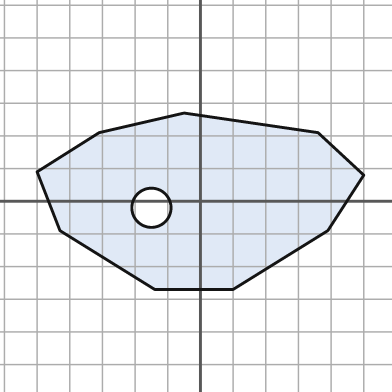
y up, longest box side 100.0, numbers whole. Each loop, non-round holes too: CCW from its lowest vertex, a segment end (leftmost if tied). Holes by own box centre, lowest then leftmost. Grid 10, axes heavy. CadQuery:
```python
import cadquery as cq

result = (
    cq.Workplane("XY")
    .moveTo(-14.0, -27.0)
    .lineTo(10.0, -27.0)
    .lineTo(39.0, -9.0)
    .lineTo(50.0, 8.0)
    .lineTo(36.0, 21.0)
    .lineTo(-5.0, 27.0)
    .lineTo(-31.0, 21.0)
    .lineTo(-50.0, 9.0)
    .lineTo(-43.0, -9.0)
    .close()
    .moveTo(-15.0, -2.0)
    .circle(6.0)
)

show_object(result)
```